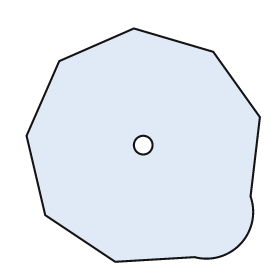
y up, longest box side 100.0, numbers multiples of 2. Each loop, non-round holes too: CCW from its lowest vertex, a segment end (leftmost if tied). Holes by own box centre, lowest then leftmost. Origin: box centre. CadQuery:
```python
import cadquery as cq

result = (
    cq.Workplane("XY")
    .moveTo(-12.0, -50.0)
    .lineTo(22.0, -48.0)
    .threePointArc((42.0, -42.0), (46.0, -22.0))
    .lineTo(50.0, 12.0)
    .lineTo(30.0, 40.0)
    .lineTo(-4.0, 50.0)
    .lineTo(-36.0, 36.0)
    .lineTo(-50.0, 4.0)
    .lineTo(-42.0, -30.0)
    .close()
    .moveTo(0.0, 0.0)
    .circle(4.0)
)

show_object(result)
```